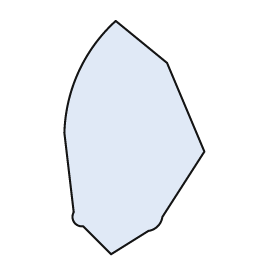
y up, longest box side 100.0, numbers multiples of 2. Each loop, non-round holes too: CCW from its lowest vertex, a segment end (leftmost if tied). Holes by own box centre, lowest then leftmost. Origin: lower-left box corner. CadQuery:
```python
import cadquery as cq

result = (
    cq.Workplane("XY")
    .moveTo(20.0, 0.0)
    .lineTo(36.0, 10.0)
    .threePointArc((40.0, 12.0), (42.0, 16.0))
    .lineTo(60.0, 44.0)
    .lineTo(44.0, 82.0)
    .lineTo(22.0, 100.0)
    .threePointArc((6.0, 78.0), (0.0, 52.0))
    .lineTo(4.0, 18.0)
    .threePointArc((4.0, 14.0), (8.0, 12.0))
    .close()
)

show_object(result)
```